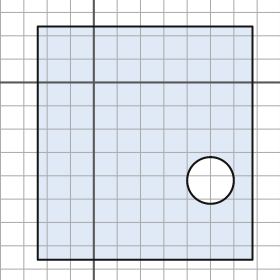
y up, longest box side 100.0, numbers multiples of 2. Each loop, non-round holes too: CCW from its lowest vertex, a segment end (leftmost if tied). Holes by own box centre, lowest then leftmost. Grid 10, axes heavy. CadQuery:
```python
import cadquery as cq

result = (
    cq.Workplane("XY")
    .moveTo(-24.0, -76.0)
    .lineTo(68.0, -76.0)
    .lineTo(68.0, 24.0)
    .lineTo(-24.0, 24.0)
    .close()
    .moveTo(50.0, -42.0)
    .circle(10.0)
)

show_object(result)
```